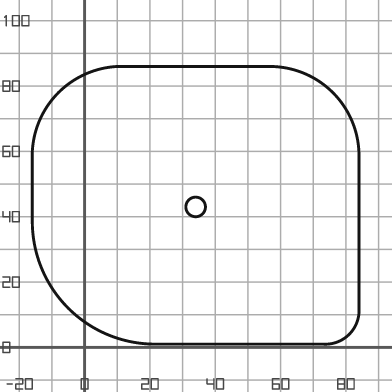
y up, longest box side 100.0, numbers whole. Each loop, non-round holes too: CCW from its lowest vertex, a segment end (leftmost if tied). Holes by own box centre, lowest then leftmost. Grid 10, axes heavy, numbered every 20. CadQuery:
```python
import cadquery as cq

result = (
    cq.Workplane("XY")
    .moveTo(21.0, 1.0)
    .lineTo(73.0, 1.0)
    .threePointArc((81.0, 4.0), (84.0, 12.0))
    .lineTo(84.0, 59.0)
    .threePointArc((76.0, 78.0), (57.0, 86.0))
    .lineTo(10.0, 86.0)
    .threePointArc((-8.0, 78.0), (-16.0, 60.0))
    .lineTo(-16.0, 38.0)
    .threePointArc((-5.0, 12.0), (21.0, 1.0))
    .close()
    .moveTo(34.0, 43.0)
    .circle(3.0)
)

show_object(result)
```